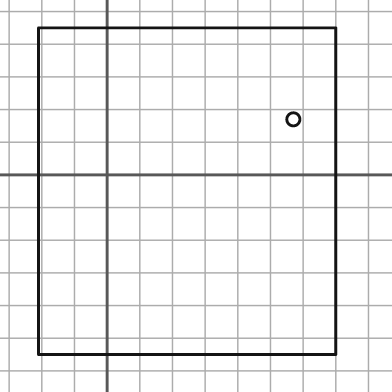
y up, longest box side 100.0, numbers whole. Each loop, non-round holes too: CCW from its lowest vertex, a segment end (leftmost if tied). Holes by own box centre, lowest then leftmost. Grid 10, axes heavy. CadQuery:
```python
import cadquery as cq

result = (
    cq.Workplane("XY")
    .moveTo(-21.0, -55.0)
    .lineTo(70.0, -55.0)
    .lineTo(70.0, 45.0)
    .lineTo(-21.0, 45.0)
    .close()
    .moveTo(57.0, 17.0)
    .circle(2.0)
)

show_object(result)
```